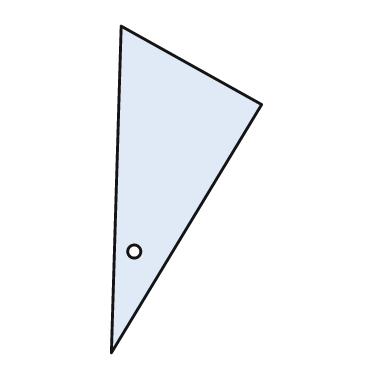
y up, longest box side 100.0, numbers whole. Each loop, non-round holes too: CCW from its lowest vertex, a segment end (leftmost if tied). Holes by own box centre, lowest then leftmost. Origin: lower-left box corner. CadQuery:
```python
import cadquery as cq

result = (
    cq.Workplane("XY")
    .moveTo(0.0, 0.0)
    .lineTo(46.0, 76.0)
    .lineTo(3.0, 100.0)
    .close()
    .moveTo(7.0, 31.0)
    .circle(2.0)
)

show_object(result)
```